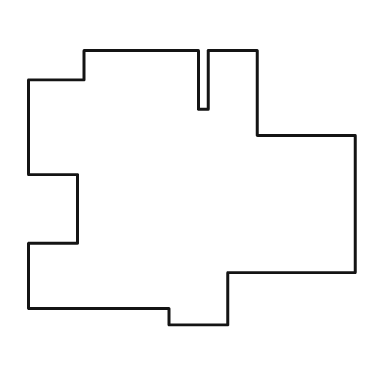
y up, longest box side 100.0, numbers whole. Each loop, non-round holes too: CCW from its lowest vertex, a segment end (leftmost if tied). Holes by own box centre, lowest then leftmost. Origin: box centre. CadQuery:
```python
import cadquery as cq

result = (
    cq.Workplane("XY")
    .moveTo(-7.0, -42.0)
    .lineTo(11.0, -42.0)
    .lineTo(11.0, -26.0)
    .lineTo(50.0, -26.0)
    .lineTo(50.0, 16.0)
    .lineTo(20.0, 16.0)
    .lineTo(20.0, 42.0)
    .lineTo(5.0, 42.0)
    .lineTo(5.0, 24.0)
    .lineTo(2.0, 24.0)
    .lineTo(2.0, 42.0)
    .lineTo(-33.0, 42.0)
    .lineTo(-33.0, 33.0)
    .lineTo(-50.0, 33.0)
    .lineTo(-50.0, 4.0)
    .lineTo(-35.0, 4.0)
    .lineTo(-35.0, -17.0)
    .lineTo(-50.0, -17.0)
    .lineTo(-50.0, -37.0)
    .lineTo(-7.0, -37.0)
    .close()
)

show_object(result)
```